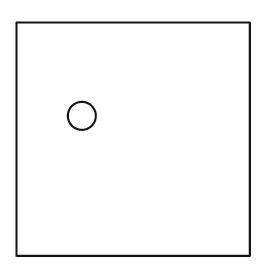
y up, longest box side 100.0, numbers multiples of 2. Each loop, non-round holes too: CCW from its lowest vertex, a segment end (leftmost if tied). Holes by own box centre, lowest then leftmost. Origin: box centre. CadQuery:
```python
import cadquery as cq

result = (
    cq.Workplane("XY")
    .moveTo(-50.0, -50.0)
    .lineTo(50.0, -50.0)
    .lineTo(50.0, 50.0)
    .lineTo(-50.0, 50.0)
    .close()
    .moveTo(-22.0, 10.0)
    .circle(6.0)
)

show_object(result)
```